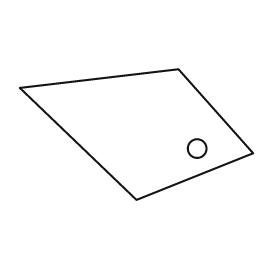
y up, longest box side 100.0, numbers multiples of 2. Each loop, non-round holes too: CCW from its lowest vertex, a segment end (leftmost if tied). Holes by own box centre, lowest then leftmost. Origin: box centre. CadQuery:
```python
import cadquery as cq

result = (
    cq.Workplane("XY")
    .moveTo(0.0, -28.0)
    .lineTo(50.0, -8.0)
    .lineTo(18.0, 28.0)
    .lineTo(-50.0, 20.0)
    .close()
    .moveTo(26.0, -6.0)
    .circle(4.0)
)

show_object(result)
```